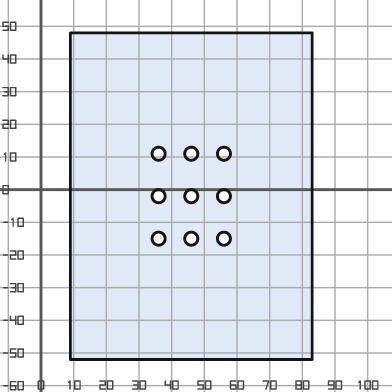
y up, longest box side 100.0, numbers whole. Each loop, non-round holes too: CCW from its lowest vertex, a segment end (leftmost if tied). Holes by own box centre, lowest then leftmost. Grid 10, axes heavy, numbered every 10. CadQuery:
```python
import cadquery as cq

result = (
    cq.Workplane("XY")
    .moveTo(9.0, -52.0)
    .lineTo(83.0, -52.0)
    .lineTo(83.0, 48.0)
    .lineTo(9.0, 48.0)
    .close()
    .moveTo(36.0, -15.0)
    .circle(2.0)
    .moveTo(46.0, -15.0)
    .circle(2.0)
    .moveTo(56.0, -15.0)
    .circle(2.0)
    .moveTo(36.0, -2.0)
    .circle(2.0)
    .moveTo(46.0, -2.0)
    .circle(2.0)
    .moveTo(56.0, -2.0)
    .circle(2.0)
    .moveTo(36.0, 11.0)
    .circle(2.0)
    .moveTo(46.0, 11.0)
    .circle(2.0)
    .moveTo(56.0, 11.0)
    .circle(2.0)
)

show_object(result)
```